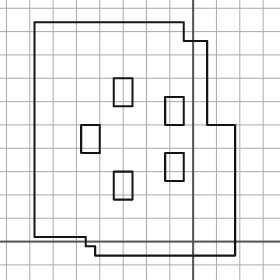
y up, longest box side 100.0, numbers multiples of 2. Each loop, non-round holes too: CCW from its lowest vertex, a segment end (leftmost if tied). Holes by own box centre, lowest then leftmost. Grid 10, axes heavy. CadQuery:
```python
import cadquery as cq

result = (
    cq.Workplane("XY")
    .moveTo(-42.0, -6.0)
    .lineTo(18.0, -6.0)
    .lineTo(18.0, 50.0)
    .lineTo(6.0, 50.0)
    .lineTo(6.0, 86.0)
    .lineTo(-4.0, 86.0)
    .lineTo(-4.0, 94.0)
    .lineTo(-68.0, 94.0)
    .lineTo(-68.0, 2.0)
    .lineTo(-46.0, 2.0)
    .lineTo(-46.0, -2.0)
    .lineTo(-42.0, -2.0)
    .close()
    .moveTo(-34.0, 18.0)
    .lineTo(-26.0, 18.0)
    .lineTo(-26.0, 30.0)
    .lineTo(-34.0, 30.0)
    .close()
    .moveTo(-12.0, 26.0)
    .lineTo(-4.0, 26.0)
    .lineTo(-4.0, 38.0)
    .lineTo(-12.0, 38.0)
    .close()
    .moveTo(-48.0, 38.0)
    .lineTo(-40.0, 38.0)
    .lineTo(-40.0, 50.0)
    .lineTo(-48.0, 50.0)
    .close()
    .moveTo(-12.0, 50.0)
    .lineTo(-4.0, 50.0)
    .lineTo(-4.0, 62.0)
    .lineTo(-12.0, 62.0)
    .close()
    .moveTo(-34.0, 58.0)
    .lineTo(-26.0, 58.0)
    .lineTo(-26.0, 70.0)
    .lineTo(-34.0, 70.0)
    .close()
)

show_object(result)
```